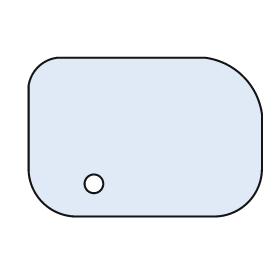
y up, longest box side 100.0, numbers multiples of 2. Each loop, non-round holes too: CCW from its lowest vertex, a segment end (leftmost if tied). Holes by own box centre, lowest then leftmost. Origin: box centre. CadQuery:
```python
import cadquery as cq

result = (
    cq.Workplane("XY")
    .moveTo(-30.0, -34.0)
    .lineTo(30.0, -34.0)
    .threePointArc((44.0, -28.0), (50.0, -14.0))
    .lineTo(50.0, 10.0)
    .threePointArc((42.0, 26.0), (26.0, 34.0))
    .lineTo(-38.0, 34.0)
    .threePointArc((-46.0, 30.0), (-50.0, 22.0))
    .lineTo(-50.0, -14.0)
    .threePointArc((-44.0, -28.0), (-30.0, -34.0))
    .close()
    .moveTo(-22.0, -20.0)
    .circle(4.0)
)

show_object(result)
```